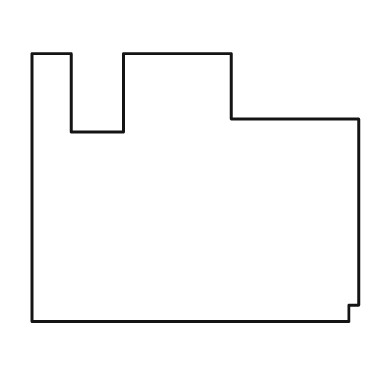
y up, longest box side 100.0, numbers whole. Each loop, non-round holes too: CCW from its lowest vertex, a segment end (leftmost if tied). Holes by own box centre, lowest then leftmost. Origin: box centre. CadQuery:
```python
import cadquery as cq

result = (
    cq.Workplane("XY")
    .moveTo(-50.0, -41.0)
    .lineTo(47.0, -41.0)
    .lineTo(47.0, -36.0)
    .lineTo(50.0, -36.0)
    .lineTo(50.0, 21.0)
    .lineTo(11.0, 21.0)
    .lineTo(11.0, 41.0)
    .lineTo(-22.0, 41.0)
    .lineTo(-22.0, 17.0)
    .lineTo(-38.0, 17.0)
    .lineTo(-38.0, 41.0)
    .lineTo(-50.0, 41.0)
    .close()
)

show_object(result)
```